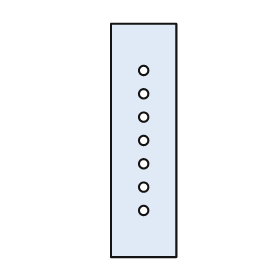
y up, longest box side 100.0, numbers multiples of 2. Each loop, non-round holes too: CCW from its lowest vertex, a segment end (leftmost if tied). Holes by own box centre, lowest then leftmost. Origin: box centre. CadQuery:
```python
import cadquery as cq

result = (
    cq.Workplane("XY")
    .moveTo(-14.0, -50.0)
    .lineTo(14.0, -50.0)
    .lineTo(14.0, 50.0)
    .lineTo(-14.0, 50.0)
    .close()
    .moveTo(0.0, -30.0)
    .circle(2.0)
    .moveTo(0.0, -20.0)
    .circle(2.0)
    .moveTo(0.0, -10.0)
    .circle(2.0)
    .moveTo(0.0, 0.0)
    .circle(2.0)
    .moveTo(0.0, 10.0)
    .circle(2.0)
    .moveTo(0.0, 20.0)
    .circle(2.0)
    .moveTo(0.0, 30.0)
    .circle(2.0)
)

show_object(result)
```